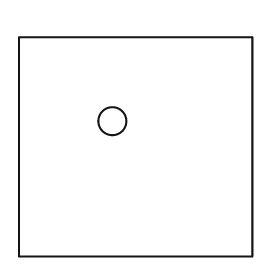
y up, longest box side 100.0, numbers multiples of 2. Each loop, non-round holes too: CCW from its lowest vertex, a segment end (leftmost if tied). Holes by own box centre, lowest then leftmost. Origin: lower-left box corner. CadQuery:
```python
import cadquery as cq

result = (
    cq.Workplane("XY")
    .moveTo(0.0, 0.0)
    .lineTo(100.0, 0.0)
    .lineTo(100.0, 94.0)
    .lineTo(0.0, 94.0)
    .close()
    .moveTo(40.0, 58.0)
    .circle(6.0)
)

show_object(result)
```